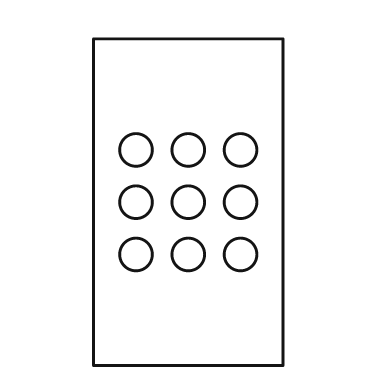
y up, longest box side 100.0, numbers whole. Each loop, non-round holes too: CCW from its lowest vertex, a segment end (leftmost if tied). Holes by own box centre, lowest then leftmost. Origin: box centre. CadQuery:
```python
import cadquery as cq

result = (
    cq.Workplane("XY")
    .moveTo(-29.0, -50.0)
    .lineTo(29.0, -50.0)
    .lineTo(29.0, 50.0)
    .lineTo(-29.0, 50.0)
    .close()
    .moveTo(-16.0, -16.0)
    .circle(5.0)
    .moveTo(0.0, -16.0)
    .circle(5.0)
    .moveTo(16.0, -16.0)
    .circle(5.0)
    .moveTo(-16.0, 0.0)
    .circle(5.0)
    .moveTo(0.0, 0.0)
    .circle(5.0)
    .moveTo(16.0, 0.0)
    .circle(5.0)
    .moveTo(-16.0, 16.0)
    .circle(5.0)
    .moveTo(0.0, 16.0)
    .circle(5.0)
    .moveTo(16.0, 16.0)
    .circle(5.0)
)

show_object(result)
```